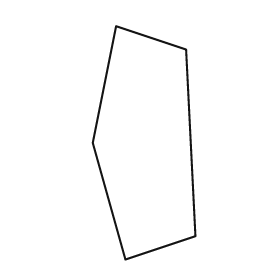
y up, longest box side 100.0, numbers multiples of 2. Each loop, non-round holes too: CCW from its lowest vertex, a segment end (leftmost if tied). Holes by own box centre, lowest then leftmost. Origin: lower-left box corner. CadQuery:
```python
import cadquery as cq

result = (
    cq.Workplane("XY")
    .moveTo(14.0, 0.0)
    .lineTo(44.0, 10.0)
    .lineTo(40.0, 90.0)
    .lineTo(10.0, 100.0)
    .lineTo(0.0, 50.0)
    .close()
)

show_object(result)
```